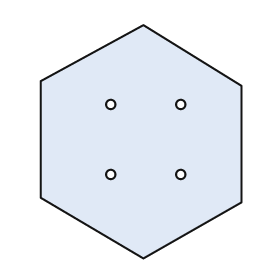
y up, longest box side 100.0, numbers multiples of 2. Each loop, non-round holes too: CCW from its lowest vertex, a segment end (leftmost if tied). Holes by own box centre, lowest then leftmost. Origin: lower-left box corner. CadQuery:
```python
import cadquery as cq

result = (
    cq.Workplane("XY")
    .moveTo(44.0, 0.0)
    .lineTo(86.0, 24.0)
    .lineTo(86.0, 74.0)
    .lineTo(44.0, 100.0)
    .lineTo(0.0, 76.0)
    .lineTo(0.0, 26.0)
    .close()
    .moveTo(30.0, 36.0)
    .circle(2.0)
    .moveTo(60.0, 36.0)
    .circle(2.0)
    .moveTo(30.0, 66.0)
    .circle(2.0)
    .moveTo(60.0, 66.0)
    .circle(2.0)
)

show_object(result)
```